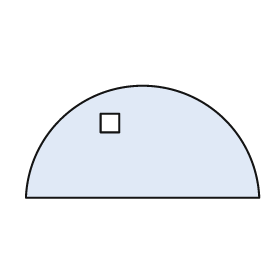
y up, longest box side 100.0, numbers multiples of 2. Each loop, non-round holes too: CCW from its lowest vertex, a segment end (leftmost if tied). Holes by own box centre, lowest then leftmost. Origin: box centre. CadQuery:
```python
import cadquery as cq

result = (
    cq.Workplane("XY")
    .moveTo(-50.0, -24.0)
    .lineTo(50.0, -24.0)
    .threePointArc((0.0, 24.0), (-50.0, -24.0))
    .close()
    .moveTo(-18.0, 4.0)
    .lineTo(-10.0, 4.0)
    .lineTo(-10.0, 12.0)
    .lineTo(-18.0, 12.0)
    .close()
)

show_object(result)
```